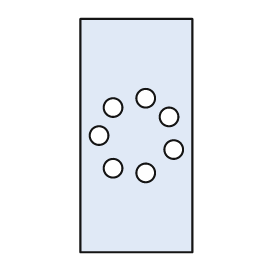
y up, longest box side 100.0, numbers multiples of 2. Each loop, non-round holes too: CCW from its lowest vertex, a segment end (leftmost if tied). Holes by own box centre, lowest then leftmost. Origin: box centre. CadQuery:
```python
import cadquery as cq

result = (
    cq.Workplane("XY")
    .moveTo(-24.0, -50.0)
    .lineTo(24.0, -50.0)
    .lineTo(24.0, 50.0)
    .lineTo(-24.0, 50.0)
    .close()
    .moveTo(4.0, -16.0)
    .circle(4.0)
    .moveTo(-10.0, -14.0)
    .circle(4.0)
    .moveTo(16.0, -6.0)
    .circle(4.0)
    .moveTo(-16.0, 0.0)
    .circle(4.0)
    .moveTo(14.0, 8.0)
    .circle(4.0)
    .moveTo(-10.0, 12.0)
    .circle(4.0)
    .moveTo(4.0, 16.0)
    .circle(4.0)
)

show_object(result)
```